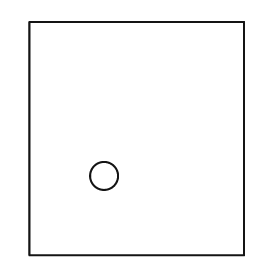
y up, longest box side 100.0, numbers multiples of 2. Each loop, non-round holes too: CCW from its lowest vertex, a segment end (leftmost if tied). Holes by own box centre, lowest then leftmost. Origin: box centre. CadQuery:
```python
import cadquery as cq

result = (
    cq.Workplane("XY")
    .moveTo(-46.0, -50.0)
    .lineTo(46.0, -50.0)
    .lineTo(46.0, 50.0)
    .lineTo(-46.0, 50.0)
    .close()
    .moveTo(-14.0, -16.0)
    .circle(6.0)
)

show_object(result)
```